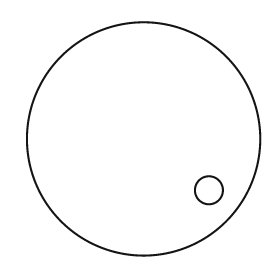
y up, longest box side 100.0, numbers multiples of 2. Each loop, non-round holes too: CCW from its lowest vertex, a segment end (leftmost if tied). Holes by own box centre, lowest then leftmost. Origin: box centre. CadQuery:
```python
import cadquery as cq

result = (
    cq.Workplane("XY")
    .moveTo(0.0, 0.0)
    .circle(50.0)
    .moveTo(28.0, -22.0)
    .circle(6.0)
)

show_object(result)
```